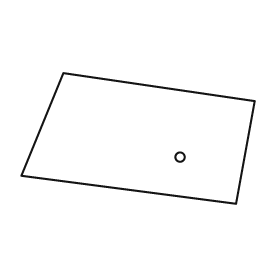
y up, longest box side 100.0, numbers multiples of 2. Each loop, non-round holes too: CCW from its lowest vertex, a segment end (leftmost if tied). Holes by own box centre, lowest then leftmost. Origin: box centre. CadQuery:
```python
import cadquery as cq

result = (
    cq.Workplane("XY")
    .moveTo(42.0, -28.0)
    .lineTo(50.0, 16.0)
    .lineTo(-32.0, 28.0)
    .lineTo(-50.0, -16.0)
    .close()
    .moveTo(18.0, -8.0)
    .circle(2.0)
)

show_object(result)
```